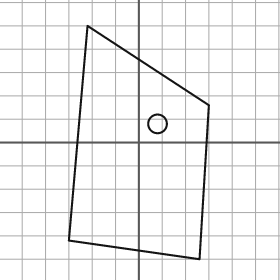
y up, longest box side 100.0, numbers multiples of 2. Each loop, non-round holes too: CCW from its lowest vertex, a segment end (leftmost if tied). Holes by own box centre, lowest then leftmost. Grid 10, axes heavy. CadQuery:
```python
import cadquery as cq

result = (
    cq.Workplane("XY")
    .moveTo(26.0, -50.0)
    .lineTo(30.0, 16.0)
    .lineTo(-22.0, 50.0)
    .lineTo(-30.0, -42.0)
    .close()
    .moveTo(8.0, 8.0)
    .circle(4.0)
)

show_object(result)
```